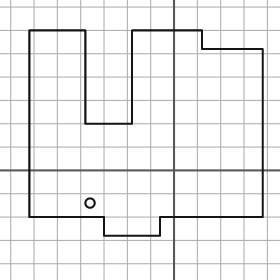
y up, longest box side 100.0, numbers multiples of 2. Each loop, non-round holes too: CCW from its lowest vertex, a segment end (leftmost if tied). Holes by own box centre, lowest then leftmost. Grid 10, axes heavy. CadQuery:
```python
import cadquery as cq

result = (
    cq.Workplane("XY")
    .moveTo(-30.0, -28.0)
    .lineTo(-6.0, -28.0)
    .lineTo(-6.0, -20.0)
    .lineTo(38.0, -20.0)
    .lineTo(38.0, 52.0)
    .lineTo(12.0, 52.0)
    .lineTo(12.0, 60.0)
    .lineTo(-18.0, 60.0)
    .lineTo(-18.0, 20.0)
    .lineTo(-38.0, 20.0)
    .lineTo(-38.0, 60.0)
    .lineTo(-62.0, 60.0)
    .lineTo(-62.0, -20.0)
    .lineTo(-30.0, -20.0)
    .close()
    .moveTo(-36.0, -14.0)
    .circle(2.0)
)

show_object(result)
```